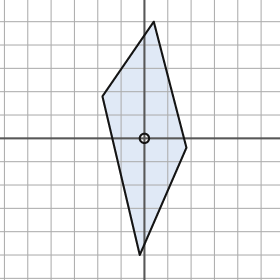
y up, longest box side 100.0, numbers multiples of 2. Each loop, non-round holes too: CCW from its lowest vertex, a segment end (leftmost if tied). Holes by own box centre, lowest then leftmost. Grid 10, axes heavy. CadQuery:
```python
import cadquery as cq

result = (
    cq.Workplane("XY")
    .moveTo(-2.0, -50.0)
    .lineTo(18.0, -4.0)
    .lineTo(4.0, 50.0)
    .lineTo(-18.0, 18.0)
    .close()
    .moveTo(0.0, 0.0)
    .circle(2.0)
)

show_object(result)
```